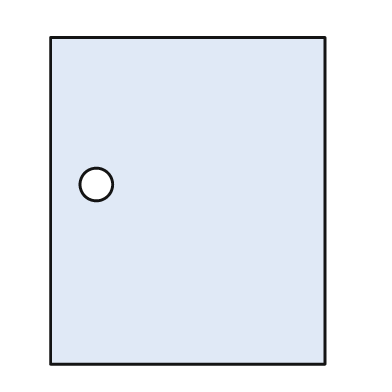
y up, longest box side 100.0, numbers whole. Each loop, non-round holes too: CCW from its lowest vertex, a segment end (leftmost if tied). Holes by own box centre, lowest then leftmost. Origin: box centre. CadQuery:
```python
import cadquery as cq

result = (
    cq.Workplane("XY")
    .moveTo(-42.0, -50.0)
    .lineTo(42.0, -50.0)
    .lineTo(42.0, 50.0)
    .lineTo(-42.0, 50.0)
    .close()
    .moveTo(-28.0, 5.0)
    .circle(5.0)
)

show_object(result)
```